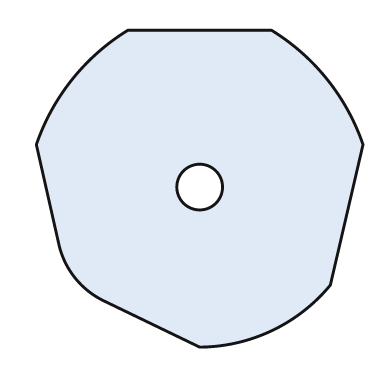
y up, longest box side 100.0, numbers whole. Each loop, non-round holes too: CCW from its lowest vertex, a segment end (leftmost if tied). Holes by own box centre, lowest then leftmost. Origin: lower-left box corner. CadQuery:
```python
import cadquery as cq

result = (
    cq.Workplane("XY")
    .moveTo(50.0, 0.0)
    .threePointArc((72.0, 5.0), (90.0, 19.0))
    .lineTo(100.0, 62.0)
    .threePointArc((89.0, 82.0), (72.0, 97.0))
    .lineTo(28.0, 97.0)
    .threePointArc((11.0, 82.0), (0.0, 62.0))
    .lineTo(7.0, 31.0)
    .threePointArc((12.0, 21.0), (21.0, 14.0))
    .close()
    .moveTo(50.0, 49.0)
    .circle(7.0)
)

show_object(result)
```